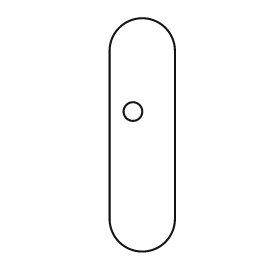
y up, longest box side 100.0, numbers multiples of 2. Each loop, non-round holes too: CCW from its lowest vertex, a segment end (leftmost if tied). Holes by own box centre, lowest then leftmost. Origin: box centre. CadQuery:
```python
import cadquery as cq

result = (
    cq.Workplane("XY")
    .moveTo(-14.0, -36.0)
    .threePointArc((0.0, -50.0), (14.0, -36.0))
    .lineTo(14.0, 36.0)
    .threePointArc((0.0, 50.0), (-14.0, 36.0))
    .close()
    .moveTo(-4.0, 10.0)
    .circle(4.0)
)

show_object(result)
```